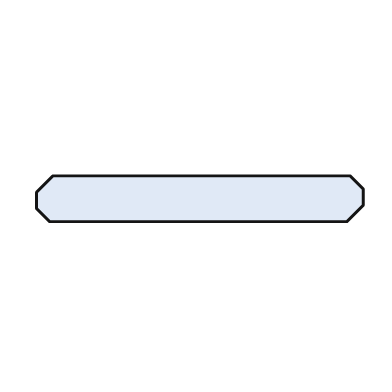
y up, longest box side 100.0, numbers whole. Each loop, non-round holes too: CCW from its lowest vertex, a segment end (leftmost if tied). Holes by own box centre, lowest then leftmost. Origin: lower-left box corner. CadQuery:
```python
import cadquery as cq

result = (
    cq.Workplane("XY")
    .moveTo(4.0, 0.0)
    .lineTo(95.0, 0.0)
    .lineTo(100.0, 5.0)
    .lineTo(100.0, 10.0)
    .lineTo(96.0, 14.0)
    .lineTo(5.0, 14.0)
    .lineTo(0.0, 9.0)
    .lineTo(0.0, 4.0)
    .close()
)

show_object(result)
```